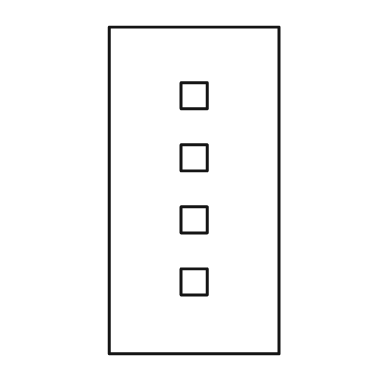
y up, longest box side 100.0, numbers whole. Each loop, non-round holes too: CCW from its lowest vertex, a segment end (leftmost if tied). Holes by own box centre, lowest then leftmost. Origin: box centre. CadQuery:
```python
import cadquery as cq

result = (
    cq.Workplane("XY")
    .moveTo(-26.0, -50.0)
    .lineTo(26.0, -50.0)
    .lineTo(26.0, 50.0)
    .lineTo(-26.0, 50.0)
    .close()
    .moveTo(-4.0, -32.0)
    .lineTo(4.0, -32.0)
    .lineTo(4.0, -24.0)
    .lineTo(-4.0, -24.0)
    .close()
    .moveTo(-4.0, -13.0)
    .lineTo(4.0, -13.0)
    .lineTo(4.0, -5.0)
    .lineTo(-4.0, -5.0)
    .close()
    .moveTo(-4.0, 6.0)
    .lineTo(4.0, 6.0)
    .lineTo(4.0, 14.0)
    .lineTo(-4.0, 14.0)
    .close()
    .moveTo(-4.0, 25.0)
    .lineTo(4.0, 25.0)
    .lineTo(4.0, 33.0)
    .lineTo(-4.0, 33.0)
    .close()
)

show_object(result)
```